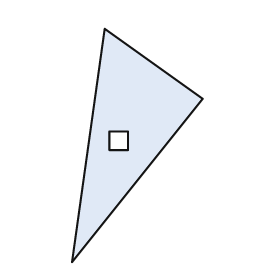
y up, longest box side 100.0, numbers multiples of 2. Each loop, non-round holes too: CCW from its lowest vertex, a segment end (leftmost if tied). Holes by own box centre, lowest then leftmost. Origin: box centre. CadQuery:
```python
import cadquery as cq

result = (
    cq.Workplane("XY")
    .moveTo(-28.0, -50.0)
    .lineTo(28.0, 20.0)
    .lineTo(-14.0, 50.0)
    .close()
    .moveTo(-12.0, -2.0)
    .lineTo(-4.0, -2.0)
    .lineTo(-4.0, 6.0)
    .lineTo(-12.0, 6.0)
    .close()
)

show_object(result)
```